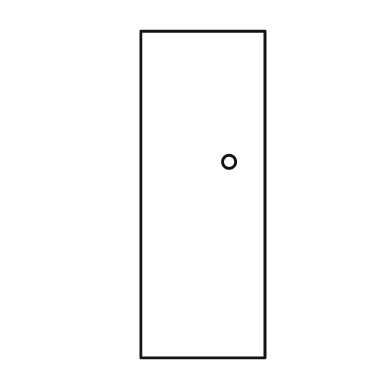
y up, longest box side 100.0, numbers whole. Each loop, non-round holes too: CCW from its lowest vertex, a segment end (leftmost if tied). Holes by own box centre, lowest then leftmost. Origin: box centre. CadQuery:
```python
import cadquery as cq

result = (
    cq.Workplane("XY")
    .moveTo(-19.0, -50.0)
    .lineTo(19.0, -50.0)
    .lineTo(19.0, 50.0)
    .lineTo(-19.0, 50.0)
    .close()
    .moveTo(8.0, 10.0)
    .circle(2.0)
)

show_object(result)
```